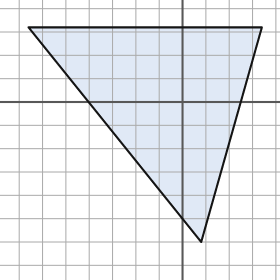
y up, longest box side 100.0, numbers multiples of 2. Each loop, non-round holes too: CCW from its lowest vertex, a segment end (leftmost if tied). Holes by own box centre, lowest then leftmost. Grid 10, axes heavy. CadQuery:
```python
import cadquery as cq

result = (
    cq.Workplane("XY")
    .moveTo(8.0, -60.0)
    .lineTo(34.0, 32.0)
    .lineTo(-66.0, 32.0)
    .close()
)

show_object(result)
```